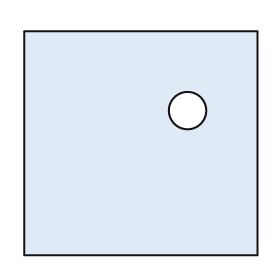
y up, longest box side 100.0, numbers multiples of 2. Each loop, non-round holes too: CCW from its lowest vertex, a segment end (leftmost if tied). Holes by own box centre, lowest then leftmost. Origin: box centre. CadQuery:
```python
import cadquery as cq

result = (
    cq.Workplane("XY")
    .moveTo(-50.0, -48.0)
    .lineTo(50.0, -48.0)
    .lineTo(50.0, 48.0)
    .lineTo(-50.0, 48.0)
    .close()
    .moveTo(20.0, 14.0)
    .circle(8.0)
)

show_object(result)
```